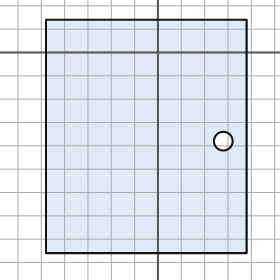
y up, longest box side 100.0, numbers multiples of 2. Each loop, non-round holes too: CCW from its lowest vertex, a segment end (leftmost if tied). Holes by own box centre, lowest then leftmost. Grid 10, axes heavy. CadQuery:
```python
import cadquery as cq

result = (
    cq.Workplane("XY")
    .moveTo(-48.0, -86.0)
    .lineTo(38.0, -86.0)
    .lineTo(38.0, 14.0)
    .lineTo(-48.0, 14.0)
    .close()
    .moveTo(28.0, -38.0)
    .circle(4.0)
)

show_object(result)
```